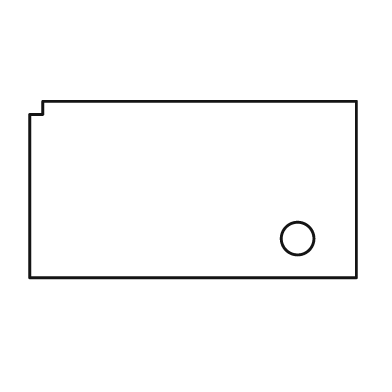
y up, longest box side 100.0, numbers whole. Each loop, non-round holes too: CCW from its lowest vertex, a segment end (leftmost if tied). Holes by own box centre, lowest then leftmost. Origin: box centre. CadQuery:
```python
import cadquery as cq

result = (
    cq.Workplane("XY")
    .moveTo(-50.0, -27.0)
    .lineTo(50.0, -27.0)
    .lineTo(50.0, 27.0)
    .lineTo(-46.0, 27.0)
    .lineTo(-46.0, 23.0)
    .lineTo(-50.0, 23.0)
    .close()
    .moveTo(32.0, -15.0)
    .circle(5.0)
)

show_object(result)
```